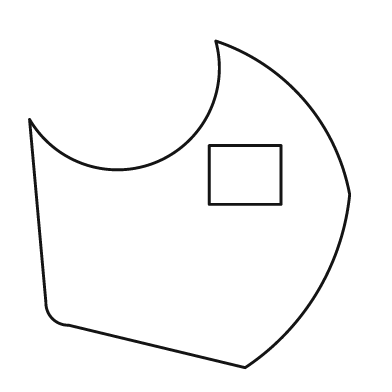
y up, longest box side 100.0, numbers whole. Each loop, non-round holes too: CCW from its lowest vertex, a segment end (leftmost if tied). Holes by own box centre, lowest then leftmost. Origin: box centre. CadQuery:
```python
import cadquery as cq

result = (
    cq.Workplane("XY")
    .moveTo(17.0, -50.0)
    .threePointArc((39.0, -27.0), (49.0, 3.0))
    .threePointArc((35.0, 32.0), (8.0, 50.0))
    .threePointArc((-10.0, 13.0), (-49.0, 26.0))
    .lineTo(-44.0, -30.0)
    .threePointArc((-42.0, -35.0), (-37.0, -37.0))
    .close()
    .moveTo(6.0, 0.0)
    .lineTo(28.0, 0.0)
    .lineTo(28.0, 18.0)
    .lineTo(6.0, 18.0)
    .close()
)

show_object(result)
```